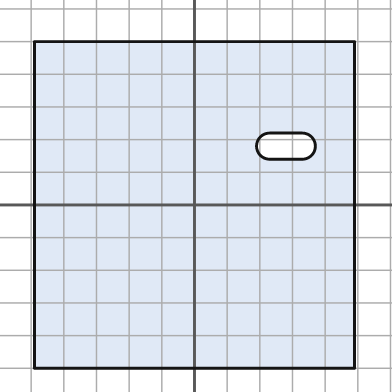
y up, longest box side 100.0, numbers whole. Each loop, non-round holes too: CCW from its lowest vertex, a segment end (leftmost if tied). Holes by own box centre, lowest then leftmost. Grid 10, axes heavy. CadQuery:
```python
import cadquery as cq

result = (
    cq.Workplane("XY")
    .moveTo(-49.0, -50.0)
    .lineTo(49.0, -50.0)
    .lineTo(49.0, 50.0)
    .lineTo(-49.0, 50.0)
    .close()
    .moveTo(23.0, 14.0)
    .lineTo(33.0, 14.0)
    .threePointArc((37.0, 18.0), (33.0, 22.0))
    .lineTo(23.0, 22.0)
    .threePointArc((19.0, 18.0), (23.0, 14.0))
    .close()
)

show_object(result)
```